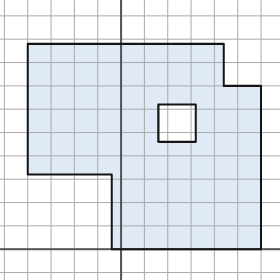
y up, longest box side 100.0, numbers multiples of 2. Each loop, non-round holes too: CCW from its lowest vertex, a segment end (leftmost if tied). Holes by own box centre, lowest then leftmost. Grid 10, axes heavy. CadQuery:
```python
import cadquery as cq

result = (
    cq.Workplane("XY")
    .moveTo(-4.0, 0.0)
    .lineTo(60.0, 0.0)
    .lineTo(60.0, 70.0)
    .lineTo(44.0, 70.0)
    .lineTo(44.0, 88.0)
    .lineTo(-40.0, 88.0)
    .lineTo(-40.0, 32.0)
    .lineTo(-4.0, 32.0)
    .close()
    .moveTo(16.0, 46.0)
    .lineTo(32.0, 46.0)
    .lineTo(32.0, 62.0)
    .lineTo(16.0, 62.0)
    .close()
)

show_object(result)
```